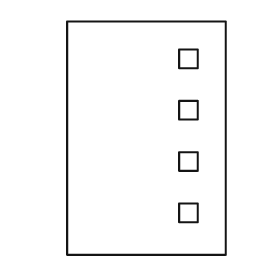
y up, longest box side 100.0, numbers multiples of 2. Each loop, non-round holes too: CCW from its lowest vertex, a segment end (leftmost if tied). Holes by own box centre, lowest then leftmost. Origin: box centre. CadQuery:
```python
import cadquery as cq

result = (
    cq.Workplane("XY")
    .moveTo(-34.0, -50.0)
    .lineTo(34.0, -50.0)
    .lineTo(34.0, 50.0)
    .lineTo(-34.0, 50.0)
    .close()
    .moveTo(14.0, -36.0)
    .lineTo(22.0, -36.0)
    .lineTo(22.0, -28.0)
    .lineTo(14.0, -28.0)
    .close()
    .moveTo(14.0, -14.0)
    .lineTo(22.0, -14.0)
    .lineTo(22.0, -6.0)
    .lineTo(14.0, -6.0)
    .close()
    .moveTo(14.0, 8.0)
    .lineTo(22.0, 8.0)
    .lineTo(22.0, 16.0)
    .lineTo(14.0, 16.0)
    .close()
    .moveTo(14.0, 30.0)
    .lineTo(22.0, 30.0)
    .lineTo(22.0, 38.0)
    .lineTo(14.0, 38.0)
    .close()
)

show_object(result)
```